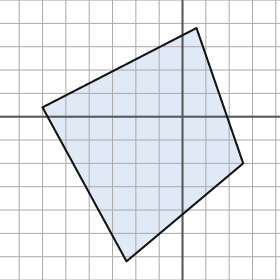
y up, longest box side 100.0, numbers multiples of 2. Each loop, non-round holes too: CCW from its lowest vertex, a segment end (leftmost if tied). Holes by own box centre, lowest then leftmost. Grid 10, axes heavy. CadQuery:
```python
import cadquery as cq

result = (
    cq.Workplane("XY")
    .moveTo(-24.0, -62.0)
    .lineTo(26.0, -20.0)
    .lineTo(6.0, 38.0)
    .lineTo(-60.0, 4.0)
    .close()
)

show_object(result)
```